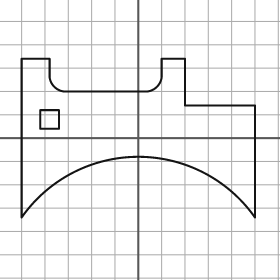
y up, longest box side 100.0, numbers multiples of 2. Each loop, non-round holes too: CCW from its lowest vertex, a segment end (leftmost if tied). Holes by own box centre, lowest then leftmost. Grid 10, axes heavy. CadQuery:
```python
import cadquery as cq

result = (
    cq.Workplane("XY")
    .moveTo(-50.0, -34.0)
    .threePointArc((0.0, -8.0), (50.0, -34.0))
    .lineTo(50.0, 14.0)
    .lineTo(20.0, 14.0)
    .lineTo(20.0, 34.0)
    .lineTo(10.0, 34.0)
    .lineTo(10.0, 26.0)
    .threePointArc((8.0, 22.0), (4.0, 20.0))
    .lineTo(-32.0, 20.0)
    .threePointArc((-36.0, 22.0), (-38.0, 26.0))
    .lineTo(-38.0, 34.0)
    .lineTo(-50.0, 34.0)
    .close()
    .moveTo(-42.0, 4.0)
    .lineTo(-34.0, 4.0)
    .lineTo(-34.0, 12.0)
    .lineTo(-42.0, 12.0)
    .close()
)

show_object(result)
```